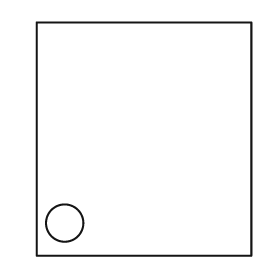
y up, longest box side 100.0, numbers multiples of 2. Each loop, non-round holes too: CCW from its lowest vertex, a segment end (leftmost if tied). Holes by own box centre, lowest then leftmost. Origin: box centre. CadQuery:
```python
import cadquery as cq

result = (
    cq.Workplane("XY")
    .moveTo(-46.0, -50.0)
    .lineTo(46.0, -50.0)
    .lineTo(46.0, 50.0)
    .lineTo(-46.0, 50.0)
    .close()
    .moveTo(-34.0, -36.0)
    .circle(8.0)
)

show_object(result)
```